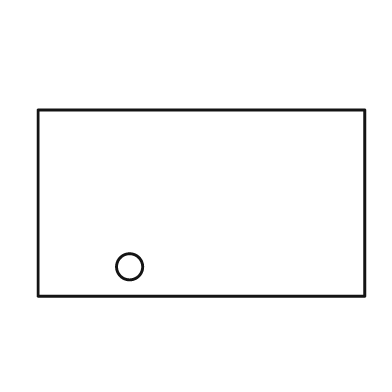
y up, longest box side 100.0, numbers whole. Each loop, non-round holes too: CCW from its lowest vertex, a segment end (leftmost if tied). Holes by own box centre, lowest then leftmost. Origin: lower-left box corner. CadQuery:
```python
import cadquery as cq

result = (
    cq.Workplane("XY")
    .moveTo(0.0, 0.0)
    .lineTo(100.0, 0.0)
    .lineTo(100.0, 57.0)
    .lineTo(0.0, 57.0)
    .close()
    .moveTo(28.0, 9.0)
    .circle(4.0)
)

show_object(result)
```